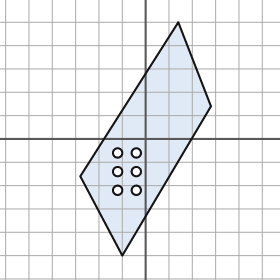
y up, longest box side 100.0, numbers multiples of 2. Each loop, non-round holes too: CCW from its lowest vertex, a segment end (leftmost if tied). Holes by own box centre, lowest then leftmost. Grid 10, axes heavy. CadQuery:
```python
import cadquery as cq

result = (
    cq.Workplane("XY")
    .moveTo(-10.0, -50.0)
    .lineTo(28.0, 14.0)
    .lineTo(14.0, 50.0)
    .lineTo(-28.0, -16.0)
    .close()
    .moveTo(-12.0, -22.0)
    .circle(2.0)
    .moveTo(-4.0, -22.0)
    .circle(2.0)
    .moveTo(-12.0, -14.0)
    .circle(2.0)
    .moveTo(-4.0, -14.0)
    .circle(2.0)
    .moveTo(-12.0, -6.0)
    .circle(2.0)
    .moveTo(-4.0, -6.0)
    .circle(2.0)
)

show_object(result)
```